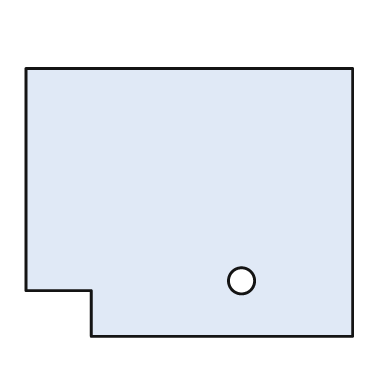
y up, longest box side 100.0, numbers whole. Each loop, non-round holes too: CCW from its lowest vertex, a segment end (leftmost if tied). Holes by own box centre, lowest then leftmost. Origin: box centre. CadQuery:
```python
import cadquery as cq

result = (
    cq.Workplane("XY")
    .moveTo(-30.0, -41.0)
    .lineTo(50.0, -41.0)
    .lineTo(50.0, 41.0)
    .lineTo(-50.0, 41.0)
    .lineTo(-50.0, -27.0)
    .lineTo(-30.0, -27.0)
    .close()
    .moveTo(16.0, -24.0)
    .circle(4.0)
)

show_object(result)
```